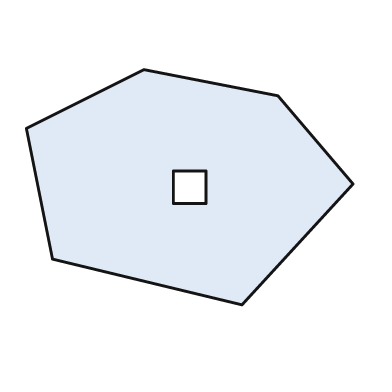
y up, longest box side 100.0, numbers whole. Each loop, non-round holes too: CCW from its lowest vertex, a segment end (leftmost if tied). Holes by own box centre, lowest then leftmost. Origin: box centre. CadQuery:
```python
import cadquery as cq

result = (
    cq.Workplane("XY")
    .moveTo(16.0, -36.0)
    .lineTo(50.0, 1.0)
    .lineTo(27.0, 28.0)
    .lineTo(-14.0, 36.0)
    .lineTo(-50.0, 18.0)
    .lineTo(-42.0, -22.0)
    .close()
    .moveTo(-5.0, -5.0)
    .lineTo(5.0, -5.0)
    .lineTo(5.0, 5.0)
    .lineTo(-5.0, 5.0)
    .close()
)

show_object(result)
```